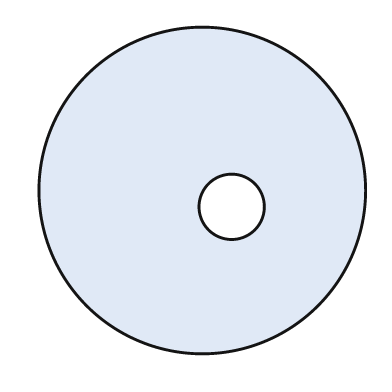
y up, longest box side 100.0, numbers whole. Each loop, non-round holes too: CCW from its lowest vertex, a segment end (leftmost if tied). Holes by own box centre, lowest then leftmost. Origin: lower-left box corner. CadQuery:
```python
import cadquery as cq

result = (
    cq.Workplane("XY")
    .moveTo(50.0, 50.0)
    .circle(50.0)
    .moveTo(59.0, 45.0)
    .circle(10.0)
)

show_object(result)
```